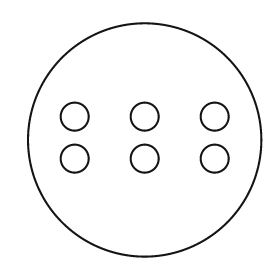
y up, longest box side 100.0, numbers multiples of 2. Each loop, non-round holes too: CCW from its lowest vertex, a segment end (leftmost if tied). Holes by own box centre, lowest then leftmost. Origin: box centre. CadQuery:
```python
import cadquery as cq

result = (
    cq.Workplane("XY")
    .moveTo(0.0, 0.0)
    .circle(50.0)
    .moveTo(-30.0, -8.0)
    .circle(6.0)
    .moveTo(0.0, -8.0)
    .circle(6.0)
    .moveTo(30.0, -8.0)
    .circle(6.0)
    .moveTo(-30.0, 10.0)
    .circle(6.0)
    .moveTo(0.0, 10.0)
    .circle(6.0)
    .moveTo(30.0, 10.0)
    .circle(6.0)
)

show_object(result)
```